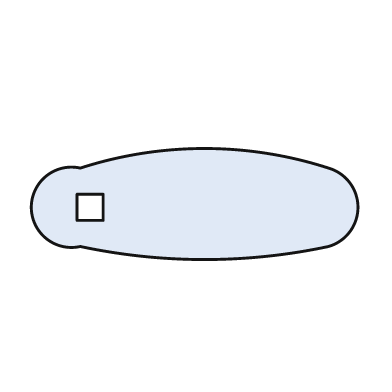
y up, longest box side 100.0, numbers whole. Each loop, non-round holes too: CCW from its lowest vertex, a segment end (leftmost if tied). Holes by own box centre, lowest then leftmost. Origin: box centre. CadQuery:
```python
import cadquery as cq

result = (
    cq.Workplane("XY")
    .moveTo(-35.0, -13.0)
    .threePointArc((3.0, -17.0), (41.0, -13.0))
    .threePointArc((50.0, -1.0), (41.0, 11.0))
    .threePointArc((3.0, 17.0), (-35.0, 11.0))
    .threePointArc((-50.0, -1.0), (-35.0, -13.0))
    .close()
    .moveTo(-36.0, -5.0)
    .lineTo(-28.0, -5.0)
    .lineTo(-28.0, 3.0)
    .lineTo(-36.0, 3.0)
    .close()
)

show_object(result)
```